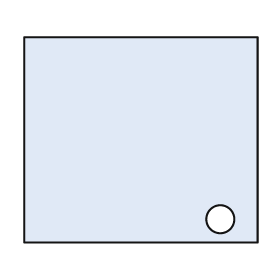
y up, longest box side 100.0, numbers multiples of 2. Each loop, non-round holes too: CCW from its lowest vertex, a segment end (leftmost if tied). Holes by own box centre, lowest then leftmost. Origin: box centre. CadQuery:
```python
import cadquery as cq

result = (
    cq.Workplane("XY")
    .moveTo(-50.0, -44.0)
    .lineTo(50.0, -44.0)
    .lineTo(50.0, 44.0)
    .lineTo(-50.0, 44.0)
    .close()
    .moveTo(34.0, -34.0)
    .circle(6.0)
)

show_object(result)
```